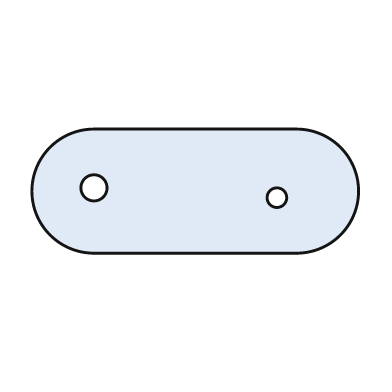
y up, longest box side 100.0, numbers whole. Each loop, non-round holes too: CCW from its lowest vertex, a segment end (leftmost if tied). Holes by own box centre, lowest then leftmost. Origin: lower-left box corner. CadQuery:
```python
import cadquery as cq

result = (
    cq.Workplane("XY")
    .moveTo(19.0, 0.0)
    .lineTo(81.0, 0.0)
    .threePointArc((100.0, 19.0), (81.0, 38.0))
    .lineTo(19.0, 38.0)
    .threePointArc((0.0, 19.0), (19.0, 0.0))
    .close()
    .moveTo(75.0, 17.0)
    .circle(3.0)
    .moveTo(19.0, 20.0)
    .circle(4.0)
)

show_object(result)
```